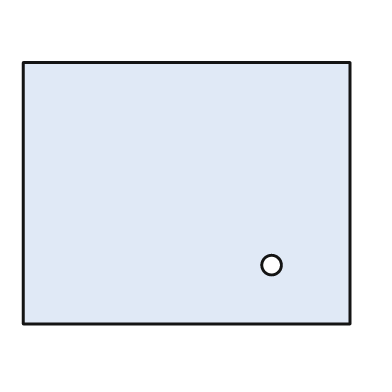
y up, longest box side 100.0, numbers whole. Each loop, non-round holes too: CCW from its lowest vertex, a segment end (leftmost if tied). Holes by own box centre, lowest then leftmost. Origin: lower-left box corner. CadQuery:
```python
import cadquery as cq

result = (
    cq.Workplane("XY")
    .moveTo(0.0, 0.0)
    .lineTo(100.0, 0.0)
    .lineTo(100.0, 80.0)
    .lineTo(0.0, 80.0)
    .close()
    .moveTo(76.0, 18.0)
    .circle(3.0)
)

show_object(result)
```